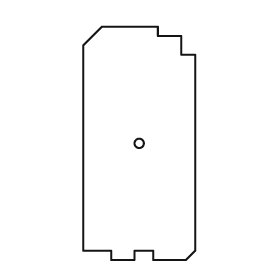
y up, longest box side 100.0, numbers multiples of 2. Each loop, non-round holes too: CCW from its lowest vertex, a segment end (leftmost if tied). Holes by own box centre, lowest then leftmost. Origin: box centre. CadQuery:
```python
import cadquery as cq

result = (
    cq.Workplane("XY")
    .moveTo(-12.0, -50.0)
    .lineTo(-2.0, -50.0)
    .lineTo(-2.0, -46.0)
    .lineTo(6.0, -46.0)
    .lineTo(6.0, -50.0)
    .lineTo(20.0, -50.0)
    .lineTo(24.0, -46.0)
    .lineTo(24.0, 38.0)
    .lineTo(18.0, 38.0)
    .lineTo(18.0, 46.0)
    .lineTo(8.0, 46.0)
    .lineTo(8.0, 50.0)
    .lineTo(-16.0, 50.0)
    .lineTo(-24.0, 42.0)
    .lineTo(-24.0, -46.0)
    .lineTo(-12.0, -46.0)
    .close()
    .moveTo(0.0, 0.0)
    .circle(2.0)
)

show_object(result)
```